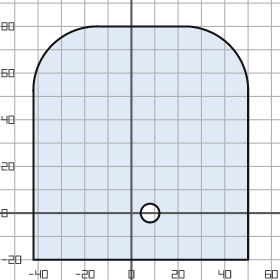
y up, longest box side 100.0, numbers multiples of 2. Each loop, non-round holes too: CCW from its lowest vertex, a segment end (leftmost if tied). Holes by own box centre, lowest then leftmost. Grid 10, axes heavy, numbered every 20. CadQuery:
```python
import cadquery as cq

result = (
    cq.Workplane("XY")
    .moveTo(-42.0, -20.0)
    .lineTo(50.0, -20.0)
    .lineTo(50.0, 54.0)
    .threePointArc((42.0, 72.0), (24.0, 80.0))
    .lineTo(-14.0, 80.0)
    .threePointArc((-34.0, 72.0), (-42.0, 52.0))
    .close()
    .moveTo(8.0, 0.0)
    .circle(4.0)
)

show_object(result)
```